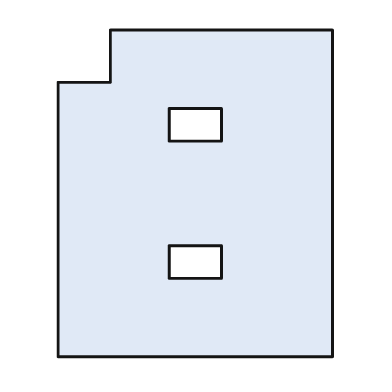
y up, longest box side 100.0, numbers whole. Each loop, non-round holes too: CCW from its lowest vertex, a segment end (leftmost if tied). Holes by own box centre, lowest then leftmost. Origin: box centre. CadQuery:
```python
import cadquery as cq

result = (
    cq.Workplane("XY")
    .moveTo(-42.0, -50.0)
    .lineTo(42.0, -50.0)
    .lineTo(42.0, 50.0)
    .lineTo(-26.0, 50.0)
    .lineTo(-26.0, 34.0)
    .lineTo(-42.0, 34.0)
    .close()
    .moveTo(-8.0, -26.0)
    .lineTo(8.0, -26.0)
    .lineTo(8.0, -16.0)
    .lineTo(-8.0, -16.0)
    .close()
    .moveTo(-8.0, 16.0)
    .lineTo(8.0, 16.0)
    .lineTo(8.0, 26.0)
    .lineTo(-8.0, 26.0)
    .close()
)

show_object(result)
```